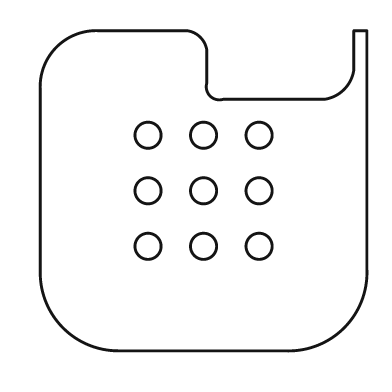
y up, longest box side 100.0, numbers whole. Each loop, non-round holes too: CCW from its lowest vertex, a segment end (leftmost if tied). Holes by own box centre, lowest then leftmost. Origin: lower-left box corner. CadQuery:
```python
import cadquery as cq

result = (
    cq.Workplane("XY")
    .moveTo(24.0, 0.0)
    .lineTo(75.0, 0.0)
    .threePointArc((93.0, 7.0), (100.0, 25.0))
    .lineTo(100.0, 98.0)
    .lineTo(96.0, 98.0)
    .lineTo(96.0, 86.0)
    .threePointArc((93.0, 80.0), (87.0, 77.0))
    .lineTo(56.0, 77.0)
    .threePointArc((52.0, 78.0), (51.0, 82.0))
    .lineTo(51.0, 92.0)
    .threePointArc((49.0, 96.0), (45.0, 98.0))
    .lineTo(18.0, 98.0)
    .threePointArc((5.0, 93.0), (0.0, 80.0))
    .lineTo(0.0, 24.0)
    .threePointArc((7.0, 7.0), (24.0, 0.0))
    .close()
    .moveTo(33.0, 32.0)
    .circle(4.0)
    .moveTo(50.0, 32.0)
    .circle(4.0)
    .moveTo(67.0, 32.0)
    .circle(4.0)
    .moveTo(33.0, 49.0)
    .circle(4.0)
    .moveTo(50.0, 49.0)
    .circle(4.0)
    .moveTo(67.0, 49.0)
    .circle(4.0)
    .moveTo(33.0, 66.0)
    .circle(4.0)
    .moveTo(50.0, 66.0)
    .circle(4.0)
    .moveTo(67.0, 66.0)
    .circle(4.0)
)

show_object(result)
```